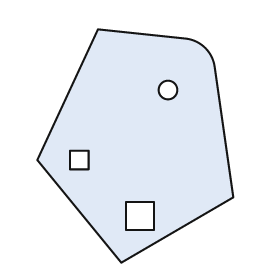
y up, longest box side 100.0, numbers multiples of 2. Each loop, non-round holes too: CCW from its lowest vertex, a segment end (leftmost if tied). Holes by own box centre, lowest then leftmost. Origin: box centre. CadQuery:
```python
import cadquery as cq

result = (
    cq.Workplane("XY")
    .moveTo(-6.0, -50.0)
    .lineTo(42.0, -22.0)
    .lineTo(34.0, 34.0)
    .threePointArc((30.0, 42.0), (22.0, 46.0))
    .lineTo(-16.0, 50.0)
    .lineTo(-42.0, -6.0)
    .close()
    .moveTo(-4.0, -36.0)
    .lineTo(8.0, -36.0)
    .lineTo(8.0, -24.0)
    .lineTo(-4.0, -24.0)
    .close()
    .moveTo(-28.0, -10.0)
    .lineTo(-20.0, -10.0)
    .lineTo(-20.0, -2.0)
    .lineTo(-28.0, -2.0)
    .close()
    .moveTo(14.0, 24.0)
    .circle(4.0)
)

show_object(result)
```